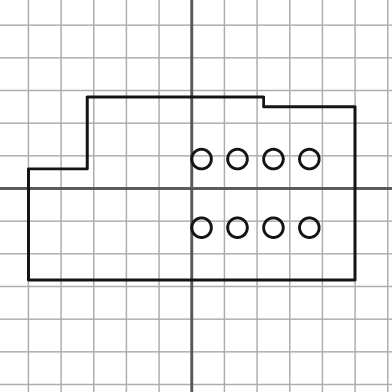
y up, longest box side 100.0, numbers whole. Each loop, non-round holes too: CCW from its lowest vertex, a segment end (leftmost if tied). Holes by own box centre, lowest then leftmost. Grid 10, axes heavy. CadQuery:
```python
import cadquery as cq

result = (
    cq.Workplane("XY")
    .moveTo(-50.0, -28.0)
    .lineTo(50.0, -28.0)
    .lineTo(50.0, 25.0)
    .lineTo(22.0, 25.0)
    .lineTo(22.0, 28.0)
    .lineTo(-32.0, 28.0)
    .lineTo(-32.0, 6.0)
    .lineTo(-50.0, 6.0)
    .close()
    .moveTo(3.0, -12.0)
    .circle(3.0)
    .moveTo(14.0, -12.0)
    .circle(3.0)
    .moveTo(25.0, -12.0)
    .circle(3.0)
    .moveTo(36.0, -12.0)
    .circle(3.0)
    .moveTo(3.0, 9.0)
    .circle(3.0)
    .moveTo(14.0, 9.0)
    .circle(3.0)
    .moveTo(25.0, 9.0)
    .circle(3.0)
    .moveTo(36.0, 9.0)
    .circle(3.0)
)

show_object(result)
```